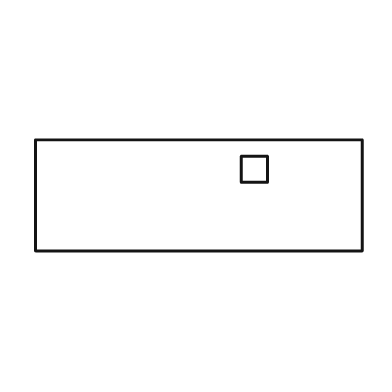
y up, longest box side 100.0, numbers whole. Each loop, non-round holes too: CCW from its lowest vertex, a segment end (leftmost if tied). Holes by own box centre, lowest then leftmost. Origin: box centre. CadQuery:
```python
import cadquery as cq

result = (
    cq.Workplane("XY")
    .moveTo(-50.0, -17.0)
    .lineTo(50.0, -17.0)
    .lineTo(50.0, 17.0)
    .lineTo(-50.0, 17.0)
    .close()
    .moveTo(13.0, 4.0)
    .lineTo(21.0, 4.0)
    .lineTo(21.0, 12.0)
    .lineTo(13.0, 12.0)
    .close()
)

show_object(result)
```